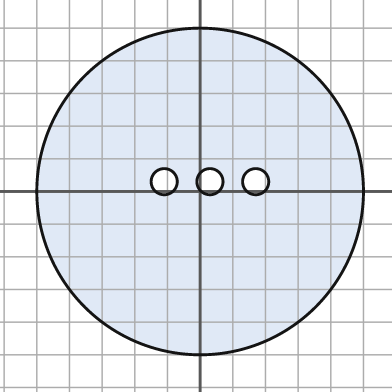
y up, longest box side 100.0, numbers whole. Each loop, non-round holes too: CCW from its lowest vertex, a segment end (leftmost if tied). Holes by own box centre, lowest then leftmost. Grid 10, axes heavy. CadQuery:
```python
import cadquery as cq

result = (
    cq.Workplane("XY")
    .moveTo(0.0, 0.0)
    .circle(50.0)
    .moveTo(-11.0, 3.0)
    .circle(4.0)
    .moveTo(3.0, 3.0)
    .circle(4.0)
    .moveTo(17.0, 3.0)
    .circle(4.0)
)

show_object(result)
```